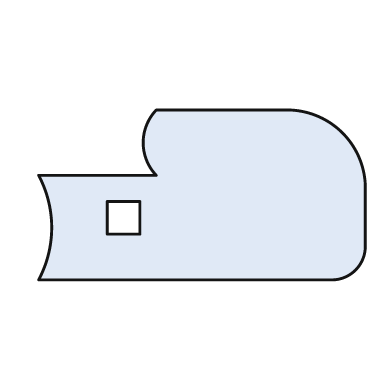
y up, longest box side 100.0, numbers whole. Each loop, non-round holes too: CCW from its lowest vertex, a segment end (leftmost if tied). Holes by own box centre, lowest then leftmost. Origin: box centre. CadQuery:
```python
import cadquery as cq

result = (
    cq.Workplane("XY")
    .moveTo(-50.0, -26.0)
    .lineTo(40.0, -26.0)
    .threePointArc((47.0, -23.0), (50.0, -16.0))
    .lineTo(50.0, 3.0)
    .threePointArc((43.0, 19.0), (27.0, 26.0))
    .lineTo(-14.0, 26.0)
    .threePointArc((-18.0, 16.0), (-14.0, 6.0))
    .lineTo(-50.0, 6.0)
    .threePointArc((-46.0, -10.0), (-50.0, -26.0))
    .close()
    .moveTo(-29.0, -12.0)
    .lineTo(-19.0, -12.0)
    .lineTo(-19.0, -2.0)
    .lineTo(-29.0, -2.0)
    .close()
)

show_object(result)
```